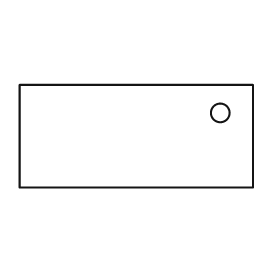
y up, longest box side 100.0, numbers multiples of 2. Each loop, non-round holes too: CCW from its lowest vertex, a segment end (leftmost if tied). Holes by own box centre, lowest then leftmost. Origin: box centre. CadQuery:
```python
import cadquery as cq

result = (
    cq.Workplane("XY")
    .moveTo(-50.0, -22.0)
    .lineTo(50.0, -22.0)
    .lineTo(50.0, 22.0)
    .lineTo(-50.0, 22.0)
    .close()
    .moveTo(36.0, 10.0)
    .circle(4.0)
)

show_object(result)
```